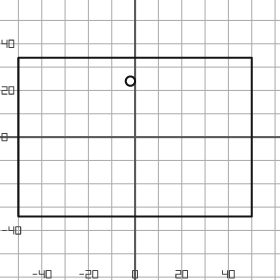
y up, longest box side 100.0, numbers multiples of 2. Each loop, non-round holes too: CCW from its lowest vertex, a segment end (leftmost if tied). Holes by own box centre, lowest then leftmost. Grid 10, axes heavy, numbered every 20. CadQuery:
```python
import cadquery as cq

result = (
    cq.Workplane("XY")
    .moveTo(-50.0, -34.0)
    .lineTo(50.0, -34.0)
    .lineTo(50.0, 34.0)
    .lineTo(-50.0, 34.0)
    .close()
    .moveTo(-2.0, 24.0)
    .circle(2.0)
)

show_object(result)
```